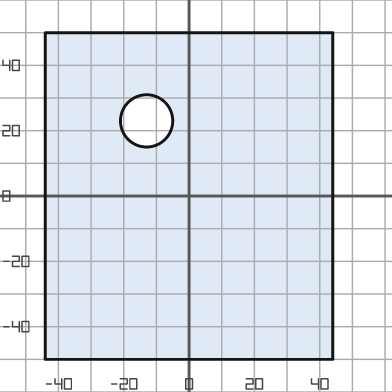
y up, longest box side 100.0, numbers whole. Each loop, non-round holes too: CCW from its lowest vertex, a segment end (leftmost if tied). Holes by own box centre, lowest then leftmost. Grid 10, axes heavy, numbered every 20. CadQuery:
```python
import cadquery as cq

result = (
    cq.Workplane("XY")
    .moveTo(-44.0, -50.0)
    .lineTo(44.0, -50.0)
    .lineTo(44.0, 50.0)
    .lineTo(-44.0, 50.0)
    .close()
    .moveTo(-13.0, 23.0)
    .circle(8.0)
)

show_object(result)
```